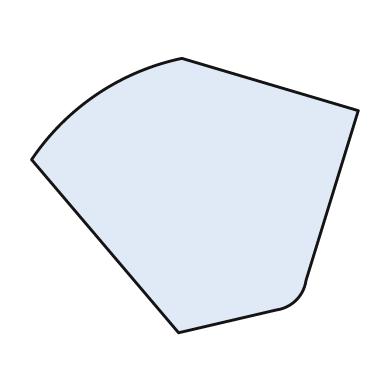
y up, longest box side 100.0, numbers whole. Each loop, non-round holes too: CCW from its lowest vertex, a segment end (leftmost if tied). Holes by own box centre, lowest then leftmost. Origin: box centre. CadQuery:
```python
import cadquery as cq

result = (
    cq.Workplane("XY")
    .moveTo(-5.0, -42.0)
    .lineTo(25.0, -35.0)
    .threePointArc((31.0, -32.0), (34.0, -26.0))
    .lineTo(50.0, 26.0)
    .lineTo(-4.0, 42.0)
    .threePointArc((-30.0, 31.0), (-50.0, 11.0))
    .close()
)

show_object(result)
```